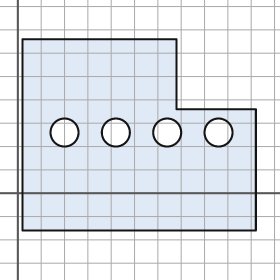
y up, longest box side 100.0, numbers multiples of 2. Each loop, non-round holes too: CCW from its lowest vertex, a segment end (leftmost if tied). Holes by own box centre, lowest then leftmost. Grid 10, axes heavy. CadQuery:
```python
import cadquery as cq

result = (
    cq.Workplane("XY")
    .moveTo(2.0, -16.0)
    .lineTo(102.0, -16.0)
    .lineTo(102.0, 36.0)
    .lineTo(68.0, 36.0)
    .lineTo(68.0, 66.0)
    .lineTo(2.0, 66.0)
    .close()
    .moveTo(20.0, 26.0)
    .circle(6.0)
    .moveTo(42.0, 26.0)
    .circle(6.0)
    .moveTo(64.0, 26.0)
    .circle(6.0)
    .moveTo(86.0, 26.0)
    .circle(6.0)
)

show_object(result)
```